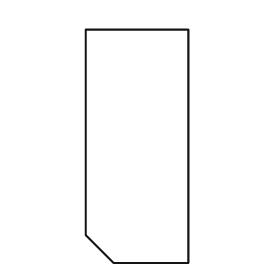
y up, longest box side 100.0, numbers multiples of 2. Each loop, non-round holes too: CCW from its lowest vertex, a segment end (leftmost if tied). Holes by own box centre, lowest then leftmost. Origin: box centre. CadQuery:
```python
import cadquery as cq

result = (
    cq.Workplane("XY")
    .moveTo(-10.0, -50.0)
    .lineTo(22.0, -50.0)
    .lineTo(22.0, 50.0)
    .lineTo(-22.0, 50.0)
    .lineTo(-22.0, -38.0)
    .close()
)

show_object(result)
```